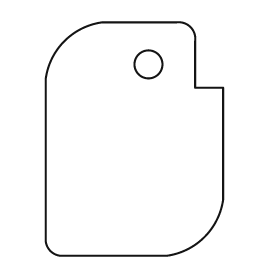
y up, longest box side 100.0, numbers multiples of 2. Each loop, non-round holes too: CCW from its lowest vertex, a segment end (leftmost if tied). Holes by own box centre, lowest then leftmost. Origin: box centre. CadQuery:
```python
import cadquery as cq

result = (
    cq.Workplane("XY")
    .moveTo(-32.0, -50.0)
    .lineTo(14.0, -50.0)
    .threePointArc((30.0, -42.0), (38.0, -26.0))
    .lineTo(38.0, 22.0)
    .lineTo(26.0, 22.0)
    .lineTo(26.0, 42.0)
    .threePointArc((24.0, 48.0), (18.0, 50.0))
    .lineTo(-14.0, 50.0)
    .threePointArc((-30.0, 42.0), (-38.0, 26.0))
    .lineTo(-38.0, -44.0)
    .threePointArc((-36.0, -48.0), (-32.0, -50.0))
    .close()
    .moveTo(6.0, 32.0)
    .circle(6.0)
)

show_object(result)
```